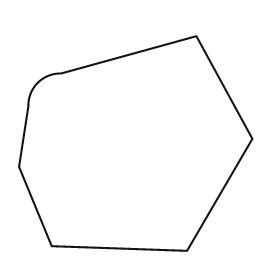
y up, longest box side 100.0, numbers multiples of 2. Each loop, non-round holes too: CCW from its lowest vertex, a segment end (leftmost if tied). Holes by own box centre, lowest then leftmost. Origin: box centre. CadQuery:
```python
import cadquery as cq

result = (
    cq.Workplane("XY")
    .moveTo(22.0, -46.0)
    .lineTo(50.0, 2.0)
    .lineTo(26.0, 46.0)
    .lineTo(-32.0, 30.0)
    .threePointArc((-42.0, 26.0), (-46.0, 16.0))
    .lineTo(-50.0, -10.0)
    .lineTo(-36.0, -44.0)
    .close()
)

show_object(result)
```